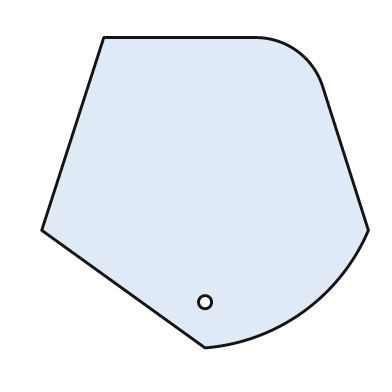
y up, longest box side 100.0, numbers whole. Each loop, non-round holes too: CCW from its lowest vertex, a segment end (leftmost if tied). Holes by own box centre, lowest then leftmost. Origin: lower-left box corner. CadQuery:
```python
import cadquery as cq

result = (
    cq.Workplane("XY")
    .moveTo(50.0, 0.0)
    .threePointArc((80.0, 11.0), (100.0, 36.0))
    .lineTo(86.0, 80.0)
    .threePointArc((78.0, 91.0), (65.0, 95.0))
    .lineTo(19.0, 95.0)
    .lineTo(0.0, 36.0)
    .close()
    .moveTo(50.0, 14.0)
    .circle(2.0)
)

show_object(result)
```